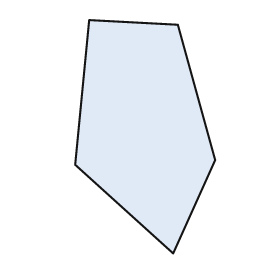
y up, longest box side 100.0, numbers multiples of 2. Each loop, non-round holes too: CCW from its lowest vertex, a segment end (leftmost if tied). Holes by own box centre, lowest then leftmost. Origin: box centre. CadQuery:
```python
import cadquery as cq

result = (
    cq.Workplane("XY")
    .moveTo(12.0, -50.0)
    .lineTo(30.0, -10.0)
    .lineTo(14.0, 48.0)
    .lineTo(-24.0, 50.0)
    .lineTo(-30.0, -12.0)
    .close()
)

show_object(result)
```